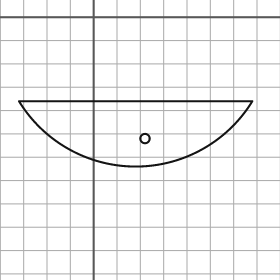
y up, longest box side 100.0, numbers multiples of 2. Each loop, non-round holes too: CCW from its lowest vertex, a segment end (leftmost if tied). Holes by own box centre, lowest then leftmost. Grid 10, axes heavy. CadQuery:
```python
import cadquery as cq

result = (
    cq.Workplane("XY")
    .moveTo(-32.0, -36.0)
    .threePointArc((18.0, -64.0), (68.0, -36.0))
    .close()
    .moveTo(22.0, -52.0)
    .circle(2.0)
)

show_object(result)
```